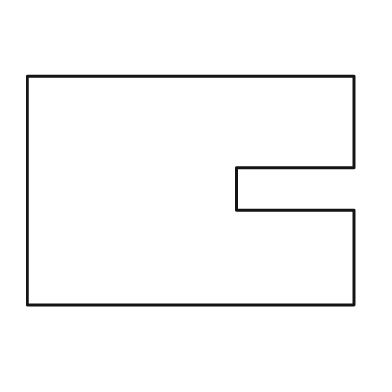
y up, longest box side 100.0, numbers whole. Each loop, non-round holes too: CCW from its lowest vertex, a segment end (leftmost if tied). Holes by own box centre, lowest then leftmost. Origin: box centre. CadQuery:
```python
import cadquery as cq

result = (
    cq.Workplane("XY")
    .moveTo(-50.0, -35.0)
    .lineTo(50.0, -35.0)
    .lineTo(50.0, -6.0)
    .lineTo(14.0, -6.0)
    .lineTo(14.0, 7.0)
    .lineTo(50.0, 7.0)
    .lineTo(50.0, 35.0)
    .lineTo(-50.0, 35.0)
    .close()
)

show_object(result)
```